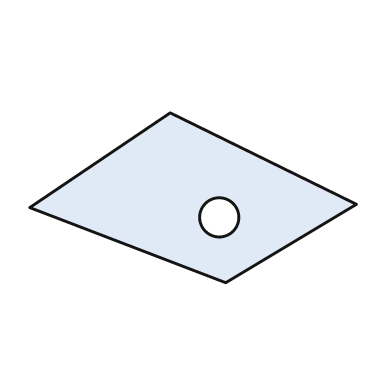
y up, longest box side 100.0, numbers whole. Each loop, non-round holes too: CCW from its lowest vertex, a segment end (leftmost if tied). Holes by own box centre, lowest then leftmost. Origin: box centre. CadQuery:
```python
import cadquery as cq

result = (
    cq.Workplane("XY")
    .moveTo(10.0, -26.0)
    .lineTo(50.0, -2.0)
    .lineTo(-7.0, 26.0)
    .lineTo(-50.0, -3.0)
    .close()
    .moveTo(8.0, -6.0)
    .circle(6.0)
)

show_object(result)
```